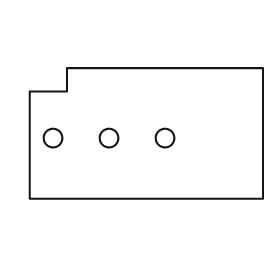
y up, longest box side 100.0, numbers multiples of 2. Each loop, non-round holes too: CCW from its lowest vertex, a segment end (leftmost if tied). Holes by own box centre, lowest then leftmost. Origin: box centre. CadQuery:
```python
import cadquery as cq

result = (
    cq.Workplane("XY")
    .moveTo(-50.0, -28.0)
    .lineTo(50.0, -28.0)
    .lineTo(50.0, 28.0)
    .lineTo(-34.0, 28.0)
    .lineTo(-34.0, 18.0)
    .lineTo(-50.0, 18.0)
    .close()
    .moveTo(-40.0, -2.0)
    .circle(4.0)
    .moveTo(-16.0, -2.0)
    .circle(4.0)
    .moveTo(8.0, -2.0)
    .circle(4.0)
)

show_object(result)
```